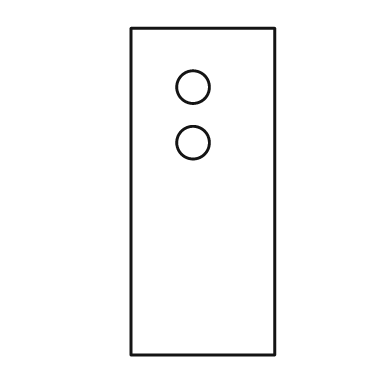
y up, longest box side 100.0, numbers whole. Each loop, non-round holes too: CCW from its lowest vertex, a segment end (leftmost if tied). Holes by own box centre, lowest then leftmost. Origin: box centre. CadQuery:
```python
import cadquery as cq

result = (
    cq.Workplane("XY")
    .moveTo(-22.0, -50.0)
    .lineTo(22.0, -50.0)
    .lineTo(22.0, 50.0)
    .lineTo(-22.0, 50.0)
    .close()
    .moveTo(-3.0, 15.0)
    .circle(5.0)
    .moveTo(-3.0, 32.0)
    .circle(5.0)
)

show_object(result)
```